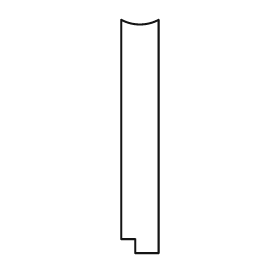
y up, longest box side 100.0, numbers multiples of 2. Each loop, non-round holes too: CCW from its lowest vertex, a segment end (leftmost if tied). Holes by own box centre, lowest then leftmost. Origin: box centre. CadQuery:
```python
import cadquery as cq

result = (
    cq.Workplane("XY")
    .moveTo(-2.0, -50.0)
    .lineTo(8.0, -50.0)
    .lineTo(8.0, 50.0)
    .threePointArc((0.0, 48.0), (-8.0, 50.0))
    .lineTo(-8.0, -44.0)
    .lineTo(-2.0, -44.0)
    .close()
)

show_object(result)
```